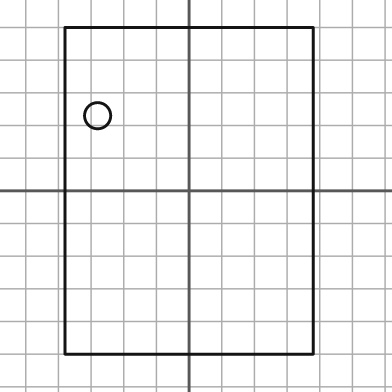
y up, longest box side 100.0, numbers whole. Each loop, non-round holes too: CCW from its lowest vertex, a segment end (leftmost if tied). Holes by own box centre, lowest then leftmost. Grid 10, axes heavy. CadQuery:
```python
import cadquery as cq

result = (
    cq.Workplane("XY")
    .moveTo(-38.0, -50.0)
    .lineTo(38.0, -50.0)
    .lineTo(38.0, 50.0)
    .lineTo(-38.0, 50.0)
    .close()
    .moveTo(-28.0, 23.0)
    .circle(4.0)
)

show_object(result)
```